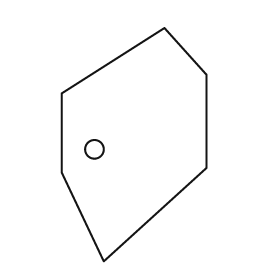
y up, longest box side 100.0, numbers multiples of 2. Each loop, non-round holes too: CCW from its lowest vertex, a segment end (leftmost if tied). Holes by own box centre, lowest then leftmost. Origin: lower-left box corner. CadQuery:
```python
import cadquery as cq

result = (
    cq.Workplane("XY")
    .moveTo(18.0, 0.0)
    .lineTo(62.0, 40.0)
    .lineTo(62.0, 80.0)
    .lineTo(44.0, 100.0)
    .lineTo(0.0, 72.0)
    .lineTo(0.0, 38.0)
    .close()
    .moveTo(14.0, 48.0)
    .circle(4.0)
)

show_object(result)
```